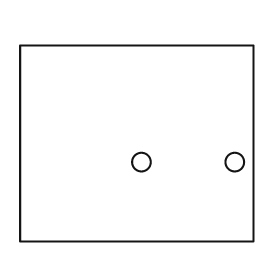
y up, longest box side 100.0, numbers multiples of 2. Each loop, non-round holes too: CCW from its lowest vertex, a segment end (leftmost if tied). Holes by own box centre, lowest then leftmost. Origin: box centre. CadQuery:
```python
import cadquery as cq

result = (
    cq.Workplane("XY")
    .moveTo(-50.0, -42.0)
    .lineTo(50.0, -42.0)
    .lineTo(50.0, 42.0)
    .lineTo(-50.0, 42.0)
    .close()
    .moveTo(2.0, -8.0)
    .circle(4.0)
    .moveTo(42.0, -8.0)
    .circle(4.0)
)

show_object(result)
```